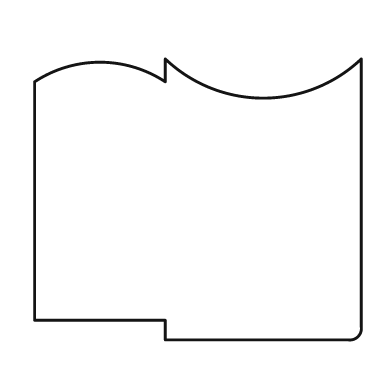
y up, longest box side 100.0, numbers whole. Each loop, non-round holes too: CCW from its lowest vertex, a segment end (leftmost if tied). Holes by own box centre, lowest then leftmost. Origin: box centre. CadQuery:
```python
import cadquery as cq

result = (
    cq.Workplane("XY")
    .moveTo(-10.0, -43.0)
    .lineTo(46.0, -43.0)
    .threePointArc((49.0, -42.0), (50.0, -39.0))
    .lineTo(50.0, 43.0)
    .threePointArc((20.0, 31.0), (-10.0, 43.0))
    .lineTo(-10.0, 36.0)
    .threePointArc((-30.0, 42.0), (-50.0, 36.0))
    .lineTo(-50.0, -37.0)
    .lineTo(-10.0, -37.0)
    .close()
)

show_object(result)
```